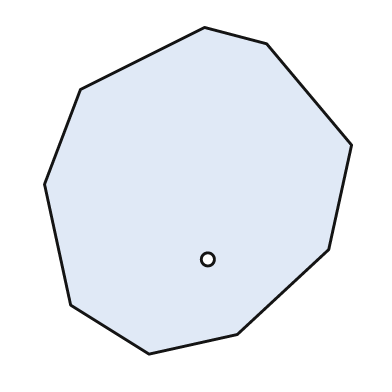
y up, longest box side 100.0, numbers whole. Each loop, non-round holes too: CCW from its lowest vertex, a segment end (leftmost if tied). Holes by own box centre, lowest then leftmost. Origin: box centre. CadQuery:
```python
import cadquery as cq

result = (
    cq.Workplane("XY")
    .moveTo(-15.0, -50.0)
    .lineTo(12.0, -44.0)
    .lineTo(40.0, -18.0)
    .lineTo(47.0, 14.0)
    .lineTo(21.0, 45.0)
    .lineTo(2.0, 50.0)
    .lineTo(-36.0, 31.0)
    .lineTo(-47.0, 2.0)
    .lineTo(-39.0, -35.0)
    .close()
    .moveTo(3.0, -21.0)
    .circle(2.0)
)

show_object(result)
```